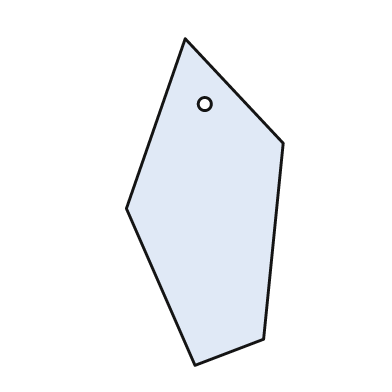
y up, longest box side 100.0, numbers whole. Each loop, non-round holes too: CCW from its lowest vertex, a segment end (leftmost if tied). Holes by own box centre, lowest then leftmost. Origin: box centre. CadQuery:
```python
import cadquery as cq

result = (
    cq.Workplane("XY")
    .moveTo(-3.0, -50.0)
    .lineTo(18.0, -42.0)
    .lineTo(24.0, 18.0)
    .lineTo(-6.0, 50.0)
    .lineTo(-24.0, -2.0)
    .close()
    .moveTo(0.0, 30.0)
    .circle(2.0)
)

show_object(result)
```